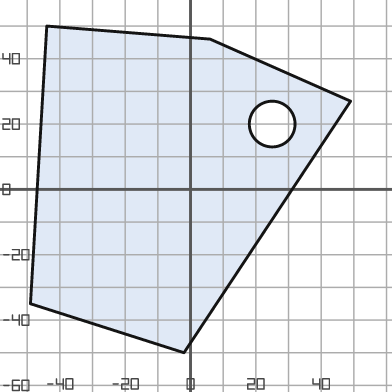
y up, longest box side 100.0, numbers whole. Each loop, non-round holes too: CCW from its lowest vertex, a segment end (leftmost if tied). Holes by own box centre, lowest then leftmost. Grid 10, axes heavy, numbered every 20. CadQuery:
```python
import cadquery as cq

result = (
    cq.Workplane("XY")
    .moveTo(-2.0, -50.0)
    .lineTo(49.0, 27.0)
    .lineTo(6.0, 46.0)
    .lineTo(-44.0, 50.0)
    .lineTo(-49.0, -35.0)
    .close()
    .moveTo(25.0, 20.0)
    .circle(7.0)
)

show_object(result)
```